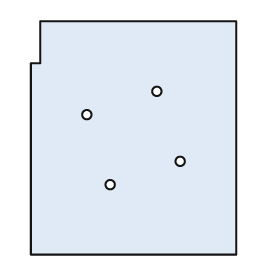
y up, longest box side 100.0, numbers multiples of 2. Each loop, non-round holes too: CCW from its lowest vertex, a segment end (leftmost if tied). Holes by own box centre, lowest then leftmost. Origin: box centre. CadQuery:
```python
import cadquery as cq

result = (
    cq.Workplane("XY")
    .moveTo(-44.0, -50.0)
    .lineTo(44.0, -50.0)
    .lineTo(44.0, 50.0)
    .lineTo(-40.0, 50.0)
    .lineTo(-40.0, 32.0)
    .lineTo(-44.0, 32.0)
    .close()
    .moveTo(-10.0, -20.0)
    .circle(2.0)
    .moveTo(20.0, -10.0)
    .circle(2.0)
    .moveTo(-20.0, 10.0)
    .circle(2.0)
    .moveTo(10.0, 20.0)
    .circle(2.0)
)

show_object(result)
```